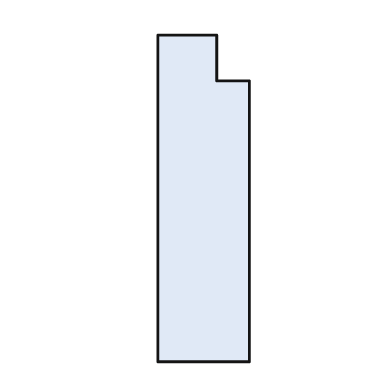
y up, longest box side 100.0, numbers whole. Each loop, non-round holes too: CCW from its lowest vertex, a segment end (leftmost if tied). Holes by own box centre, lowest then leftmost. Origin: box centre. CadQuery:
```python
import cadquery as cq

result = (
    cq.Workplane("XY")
    .moveTo(-14.0, -50.0)
    .lineTo(14.0, -50.0)
    .lineTo(14.0, 36.0)
    .lineTo(4.0, 36.0)
    .lineTo(4.0, 50.0)
    .lineTo(-14.0, 50.0)
    .close()
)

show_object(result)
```